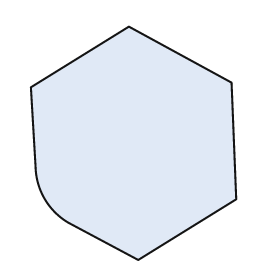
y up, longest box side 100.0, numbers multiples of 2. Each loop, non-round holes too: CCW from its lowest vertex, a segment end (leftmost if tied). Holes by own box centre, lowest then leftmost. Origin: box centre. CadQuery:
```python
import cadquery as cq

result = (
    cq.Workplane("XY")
    .moveTo(2.0, -50.0)
    .lineTo(44.0, -24.0)
    .lineTo(42.0, 26.0)
    .lineTo(-2.0, 50.0)
    .lineTo(-44.0, 24.0)
    .lineTo(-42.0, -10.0)
    .threePointArc((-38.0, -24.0), (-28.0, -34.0))
    .close()
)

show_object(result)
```